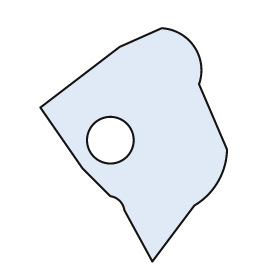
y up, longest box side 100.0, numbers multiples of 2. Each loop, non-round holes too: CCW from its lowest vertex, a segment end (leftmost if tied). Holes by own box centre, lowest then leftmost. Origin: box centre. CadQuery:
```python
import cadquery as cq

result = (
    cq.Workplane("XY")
    .moveTo(8.0, -50.0)
    .lineTo(26.0, -26.0)
    .threePointArc((36.0, -16.0), (40.0, -2.0))
    .lineTo(28.0, 26.0)
    .threePointArc((26.0, 42.0), (12.0, 50.0))
    .lineTo(-6.0, 42.0)
    .lineTo(-40.0, 16.0)
    .lineTo(-22.0, -10.0)
    .lineTo(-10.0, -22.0)
    .threePointArc((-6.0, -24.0), (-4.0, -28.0))
    .close()
    .moveTo(-10.0, 2.0)
    .circle(10.0)
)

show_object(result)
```